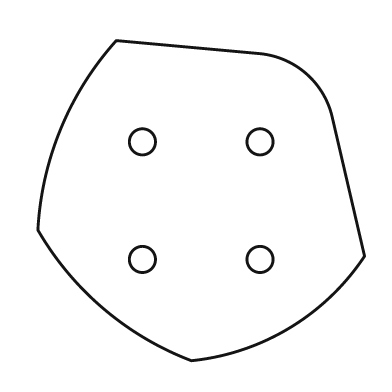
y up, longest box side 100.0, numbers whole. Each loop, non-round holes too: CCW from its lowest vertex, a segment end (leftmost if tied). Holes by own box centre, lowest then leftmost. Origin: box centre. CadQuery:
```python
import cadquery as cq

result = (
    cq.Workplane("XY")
    .moveTo(-3.0, -49.0)
    .threePointArc((27.0, -39.0), (50.0, -17.0))
    .lineTo(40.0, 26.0)
    .threePointArc((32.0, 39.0), (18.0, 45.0))
    .lineTo(-26.0, 49.0)
    .threePointArc((-43.0, 22.0), (-50.0, -9.0))
    .threePointArc((-30.0, -33.0), (-3.0, -49.0))
    .close()
    .moveTo(-18.0, -18.0)
    .circle(4.0)
    .moveTo(18.0, -18.0)
    .circle(4.0)
    .moveTo(-18.0, 18.0)
    .circle(4.0)
    .moveTo(18.0, 18.0)
    .circle(4.0)
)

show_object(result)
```